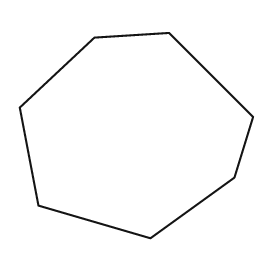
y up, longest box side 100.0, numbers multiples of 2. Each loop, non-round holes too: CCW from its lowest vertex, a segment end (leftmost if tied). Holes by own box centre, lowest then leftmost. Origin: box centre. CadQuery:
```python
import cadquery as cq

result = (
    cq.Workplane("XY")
    .moveTo(6.0, -44.0)
    .lineTo(42.0, -18.0)
    .lineTo(50.0, 8.0)
    .lineTo(14.0, 44.0)
    .lineTo(-18.0, 42.0)
    .lineTo(-50.0, 12.0)
    .lineTo(-42.0, -30.0)
    .close()
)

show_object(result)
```